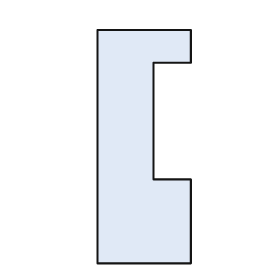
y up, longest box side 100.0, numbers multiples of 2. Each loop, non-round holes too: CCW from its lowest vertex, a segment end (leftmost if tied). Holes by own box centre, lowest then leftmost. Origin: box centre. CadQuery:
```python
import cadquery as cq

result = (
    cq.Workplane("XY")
    .moveTo(-20.0, -50.0)
    .lineTo(20.0, -50.0)
    .lineTo(20.0, -14.0)
    .lineTo(4.0, -14.0)
    .lineTo(4.0, 36.0)
    .lineTo(20.0, 36.0)
    .lineTo(20.0, 50.0)
    .lineTo(-20.0, 50.0)
    .close()
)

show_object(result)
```